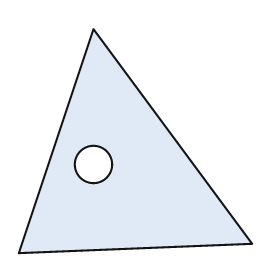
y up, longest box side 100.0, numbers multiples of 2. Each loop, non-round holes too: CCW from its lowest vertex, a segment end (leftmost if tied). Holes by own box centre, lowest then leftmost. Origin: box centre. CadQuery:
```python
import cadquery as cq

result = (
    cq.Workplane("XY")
    .moveTo(-50.0, -48.0)
    .lineTo(50.0, -44.0)
    .lineTo(-18.0, 48.0)
    .close()
    .moveTo(-18.0, -10.0)
    .circle(8.0)
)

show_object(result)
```